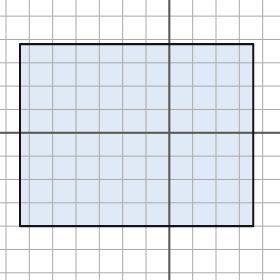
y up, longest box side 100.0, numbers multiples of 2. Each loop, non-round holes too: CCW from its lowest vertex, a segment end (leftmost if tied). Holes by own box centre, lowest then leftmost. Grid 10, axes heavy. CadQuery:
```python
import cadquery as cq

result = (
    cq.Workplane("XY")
    .moveTo(-64.0, -40.0)
    .lineTo(36.0, -40.0)
    .lineTo(36.0, 38.0)
    .lineTo(-64.0, 38.0)
    .close()
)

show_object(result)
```